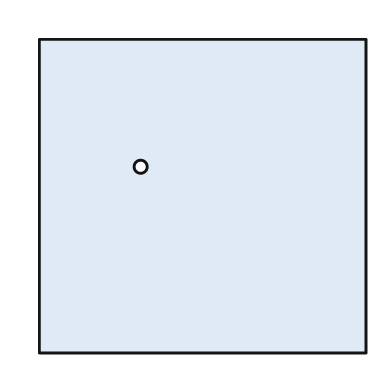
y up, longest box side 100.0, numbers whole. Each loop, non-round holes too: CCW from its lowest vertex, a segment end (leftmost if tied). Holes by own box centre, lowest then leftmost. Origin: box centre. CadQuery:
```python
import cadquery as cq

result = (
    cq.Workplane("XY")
    .moveTo(-50.0, -48.0)
    .lineTo(50.0, -48.0)
    .lineTo(50.0, 48.0)
    .lineTo(-50.0, 48.0)
    .close()
    .moveTo(-19.0, 9.0)
    .circle(2.0)
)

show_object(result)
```